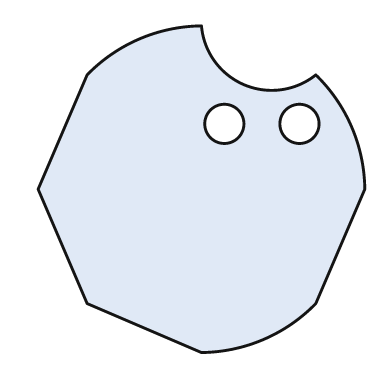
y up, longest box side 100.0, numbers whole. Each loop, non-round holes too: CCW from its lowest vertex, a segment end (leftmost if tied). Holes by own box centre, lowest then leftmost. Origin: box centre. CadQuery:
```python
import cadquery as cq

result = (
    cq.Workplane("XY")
    .moveTo(0.0, -50.0)
    .threePointArc((19.0, -46.0), (35.0, -35.0))
    .lineTo(50.0, 0.0)
    .threePointArc((46.0, 19.0), (35.0, 35.0))
    .threePointArc((13.0, 32.0), (0.0, 50.0))
    .threePointArc((-19.0, 46.0), (-35.0, 35.0))
    .lineTo(-50.0, 0.0)
    .lineTo(-35.0, -35.0)
    .close()
    .moveTo(7.0, 20.0)
    .circle(6.0)
    .moveTo(30.0, 20.0)
    .circle(6.0)
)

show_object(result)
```